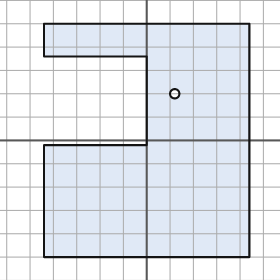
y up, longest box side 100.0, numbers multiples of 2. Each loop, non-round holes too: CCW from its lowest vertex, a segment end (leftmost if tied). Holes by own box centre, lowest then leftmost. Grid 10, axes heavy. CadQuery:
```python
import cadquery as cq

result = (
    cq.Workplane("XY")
    .moveTo(-44.0, -50.0)
    .lineTo(44.0, -50.0)
    .lineTo(44.0, 50.0)
    .lineTo(-44.0, 50.0)
    .lineTo(-44.0, 36.0)
    .lineTo(0.0, 36.0)
    .lineTo(0.0, -2.0)
    .lineTo(-44.0, -2.0)
    .close()
    .moveTo(12.0, 20.0)
    .circle(2.0)
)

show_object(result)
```